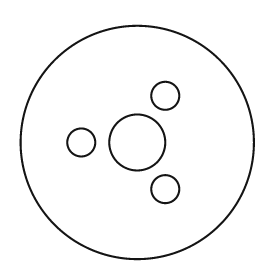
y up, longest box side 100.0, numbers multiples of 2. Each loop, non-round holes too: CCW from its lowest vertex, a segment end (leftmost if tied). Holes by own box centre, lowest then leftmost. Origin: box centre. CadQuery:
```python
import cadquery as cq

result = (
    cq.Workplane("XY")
    .moveTo(0.0, 0.0)
    .circle(50.0)
    .moveTo(12.0, -20.0)
    .circle(6.0)
    .moveTo(-24.0, 0.0)
    .circle(6.0)
    .moveTo(0.0, 0.0)
    .circle(12.0)
    .moveTo(12.0, 20.0)
    .circle(6.0)
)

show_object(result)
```